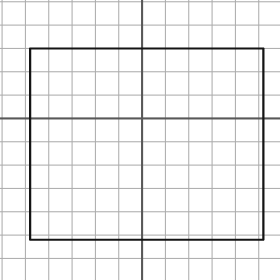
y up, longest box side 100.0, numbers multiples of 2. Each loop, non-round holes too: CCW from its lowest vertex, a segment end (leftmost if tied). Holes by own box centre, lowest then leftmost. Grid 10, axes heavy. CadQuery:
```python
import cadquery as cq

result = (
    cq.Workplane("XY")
    .moveTo(-48.0, -52.0)
    .lineTo(52.0, -52.0)
    .lineTo(52.0, 30.0)
    .lineTo(-48.0, 30.0)
    .close()
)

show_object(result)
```